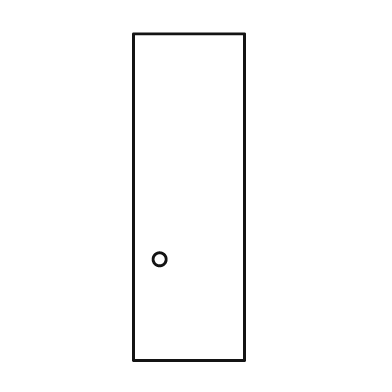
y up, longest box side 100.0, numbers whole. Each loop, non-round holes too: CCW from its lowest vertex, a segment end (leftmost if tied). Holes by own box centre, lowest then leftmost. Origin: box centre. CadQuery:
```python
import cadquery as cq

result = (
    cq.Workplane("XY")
    .moveTo(-17.0, -50.0)
    .lineTo(17.0, -50.0)
    .lineTo(17.0, 50.0)
    .lineTo(-17.0, 50.0)
    .close()
    .moveTo(-9.0, -19.0)
    .circle(2.0)
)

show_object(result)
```